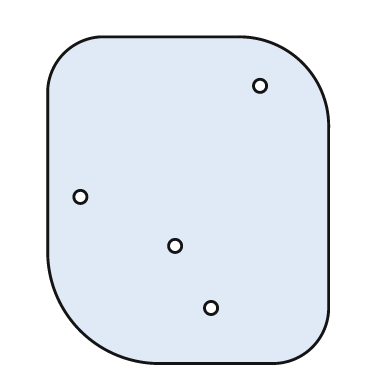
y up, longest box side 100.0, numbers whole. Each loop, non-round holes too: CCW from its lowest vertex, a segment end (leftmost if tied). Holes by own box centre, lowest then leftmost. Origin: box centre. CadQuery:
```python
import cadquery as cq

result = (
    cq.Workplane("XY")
    .moveTo(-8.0, -50.0)
    .lineTo(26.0, -50.0)
    .threePointArc((38.0, -45.0), (43.0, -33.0))
    .lineTo(43.0, 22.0)
    .threePointArc((35.0, 42.0), (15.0, 50.0))
    .lineTo(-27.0, 50.0)
    .threePointArc((-38.0, 45.0), (-43.0, 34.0))
    .lineTo(-43.0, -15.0)
    .threePointArc((-33.0, -40.0), (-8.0, -50.0))
    .close()
    .moveTo(7.0, -33.0)
    .circle(2.0)
    .moveTo(-4.0, -14.0)
    .circle(2.0)
    .moveTo(-33.0, 1.0)
    .circle(2.0)
    .moveTo(22.0, 35.0)
    .circle(2.0)
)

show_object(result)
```